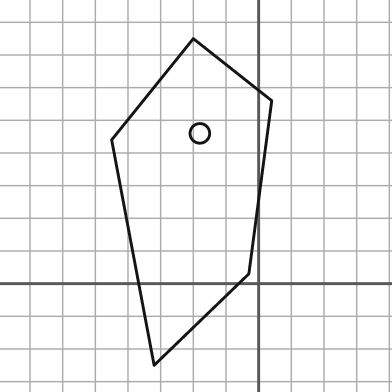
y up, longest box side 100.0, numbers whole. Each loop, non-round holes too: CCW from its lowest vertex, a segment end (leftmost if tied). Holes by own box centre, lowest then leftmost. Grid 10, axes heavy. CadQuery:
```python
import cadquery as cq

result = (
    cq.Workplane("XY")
    .moveTo(-32.0, -25.0)
    .lineTo(-3.0, 3.0)
    .lineTo(4.0, 56.0)
    .lineTo(-20.0, 75.0)
    .lineTo(-45.0, 44.0)
    .close()
    .moveTo(-18.0, 46.0)
    .circle(3.0)
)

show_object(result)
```